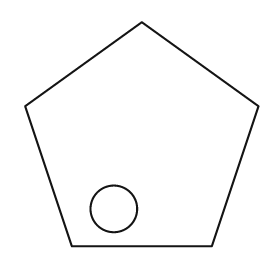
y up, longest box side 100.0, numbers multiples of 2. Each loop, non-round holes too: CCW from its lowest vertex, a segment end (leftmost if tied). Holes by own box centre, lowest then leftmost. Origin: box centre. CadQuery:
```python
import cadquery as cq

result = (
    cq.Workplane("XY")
    .moveTo(-30.0, -48.0)
    .lineTo(30.0, -48.0)
    .lineTo(50.0, 12.0)
    .lineTo(0.0, 48.0)
    .lineTo(-50.0, 12.0)
    .close()
    .moveTo(-12.0, -32.0)
    .circle(10.0)
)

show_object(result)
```